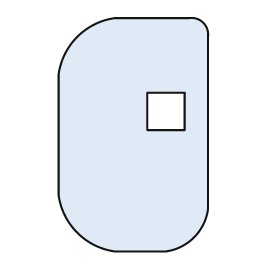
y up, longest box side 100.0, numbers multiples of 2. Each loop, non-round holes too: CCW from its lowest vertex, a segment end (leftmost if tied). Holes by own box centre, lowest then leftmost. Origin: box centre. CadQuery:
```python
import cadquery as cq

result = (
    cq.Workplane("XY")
    .moveTo(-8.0, -50.0)
    .lineTo(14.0, -50.0)
    .threePointArc((26.0, -44.0), (32.0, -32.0))
    .lineTo(32.0, 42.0)
    .threePointArc((30.0, 48.0), (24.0, 50.0))
    .lineTo(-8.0, 50.0)
    .threePointArc((-24.0, 42.0), (-32.0, 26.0))
    .lineTo(-32.0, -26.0)
    .threePointArc((-24.0, -42.0), (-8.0, -50.0))
    .close()
    .moveTo(6.0, 2.0)
    .lineTo(22.0, 2.0)
    .lineTo(22.0, 18.0)
    .lineTo(6.0, 18.0)
    .close()
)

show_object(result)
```